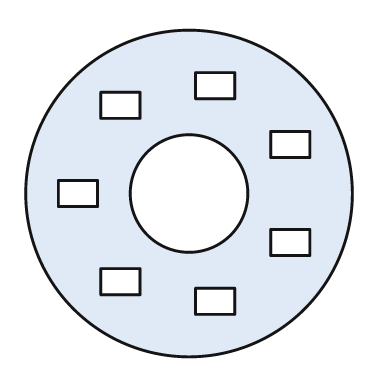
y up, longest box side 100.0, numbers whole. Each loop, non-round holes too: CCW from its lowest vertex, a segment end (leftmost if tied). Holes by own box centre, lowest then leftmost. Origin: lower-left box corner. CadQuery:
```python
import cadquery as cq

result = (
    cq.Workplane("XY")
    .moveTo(50.0, 50.0)
    .circle(50.0)
    .moveTo(52.0, 13.0)
    .lineTo(64.0, 13.0)
    .lineTo(64.0, 21.0)
    .lineTo(52.0, 21.0)
    .close()
    .moveTo(23.0, 19.0)
    .lineTo(35.0, 19.0)
    .lineTo(35.0, 27.0)
    .lineTo(23.0, 27.0)
    .close()
    .moveTo(75.0, 31.0)
    .lineTo(87.0, 31.0)
    .lineTo(87.0, 39.0)
    .lineTo(75.0, 39.0)
    .close()
    .moveTo(10.0, 46.0)
    .lineTo(22.0, 46.0)
    .lineTo(22.0, 54.0)
    .lineTo(10.0, 54.0)
    .close()
    .moveTo(50.0, 50.0)
    .circle(18.0)
    .moveTo(75.0, 61.0)
    .lineTo(87.0, 61.0)
    .lineTo(87.0, 69.0)
    .lineTo(75.0, 69.0)
    .close()
    .moveTo(23.0, 73.0)
    .lineTo(35.0, 73.0)
    .lineTo(35.0, 81.0)
    .lineTo(23.0, 81.0)
    .close()
    .moveTo(52.0, 79.0)
    .lineTo(64.0, 79.0)
    .lineTo(64.0, 87.0)
    .lineTo(52.0, 87.0)
    .close()
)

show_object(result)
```